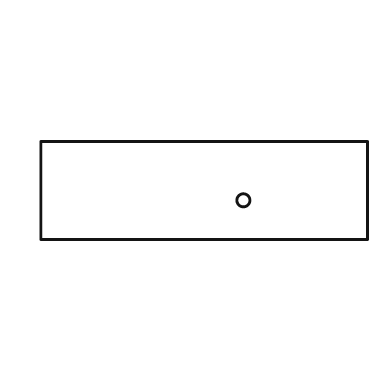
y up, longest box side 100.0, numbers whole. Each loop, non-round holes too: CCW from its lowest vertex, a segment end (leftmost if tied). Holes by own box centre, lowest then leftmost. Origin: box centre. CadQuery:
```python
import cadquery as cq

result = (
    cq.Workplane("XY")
    .moveTo(-50.0, -15.0)
    .lineTo(50.0, -15.0)
    .lineTo(50.0, 15.0)
    .lineTo(-50.0, 15.0)
    .close()
    .moveTo(12.0, -3.0)
    .circle(2.0)
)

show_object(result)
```